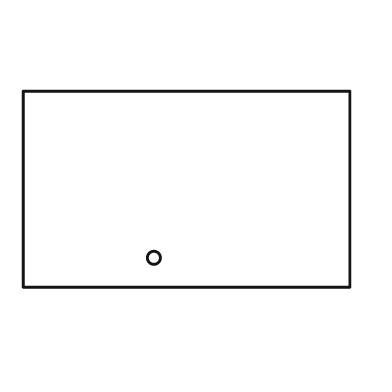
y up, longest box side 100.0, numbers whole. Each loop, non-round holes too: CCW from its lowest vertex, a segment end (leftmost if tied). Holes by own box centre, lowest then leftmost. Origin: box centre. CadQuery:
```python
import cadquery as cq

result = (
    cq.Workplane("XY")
    .moveTo(-50.0, -30.0)
    .lineTo(50.0, -30.0)
    .lineTo(50.0, 30.0)
    .lineTo(-50.0, 30.0)
    .close()
    .moveTo(-10.0, -21.0)
    .circle(2.0)
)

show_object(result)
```